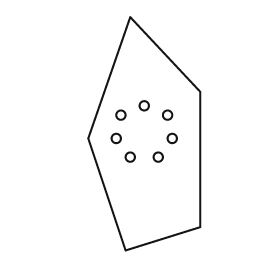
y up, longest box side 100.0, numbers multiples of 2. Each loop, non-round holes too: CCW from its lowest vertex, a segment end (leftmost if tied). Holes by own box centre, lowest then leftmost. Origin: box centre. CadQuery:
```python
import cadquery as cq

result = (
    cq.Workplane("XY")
    .moveTo(-8.0, -50.0)
    .lineTo(24.0, -40.0)
    .lineTo(24.0, 18.0)
    .lineTo(-6.0, 50.0)
    .lineTo(-24.0, -2.0)
    .close()
    .moveTo(-6.0, -10.0)
    .circle(2.0)
    .moveTo(6.0, -10.0)
    .circle(2.0)
    .moveTo(-12.0, -2.0)
    .circle(2.0)
    .moveTo(12.0, -2.0)
    .circle(2.0)
    .moveTo(-10.0, 8.0)
    .circle(2.0)
    .moveTo(10.0, 8.0)
    .circle(2.0)
    .moveTo(0.0, 12.0)
    .circle(2.0)
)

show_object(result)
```